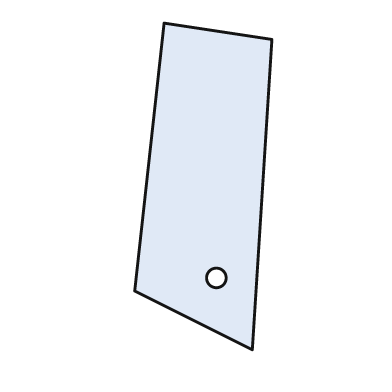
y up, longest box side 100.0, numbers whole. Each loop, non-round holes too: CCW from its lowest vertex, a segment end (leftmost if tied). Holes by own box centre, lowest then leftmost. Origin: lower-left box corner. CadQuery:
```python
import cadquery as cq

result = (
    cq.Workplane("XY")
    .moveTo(36.0, 0.0)
    .lineTo(42.0, 95.0)
    .lineTo(9.0, 100.0)
    .lineTo(0.0, 18.0)
    .close()
    .moveTo(25.0, 22.0)
    .circle(3.0)
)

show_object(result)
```